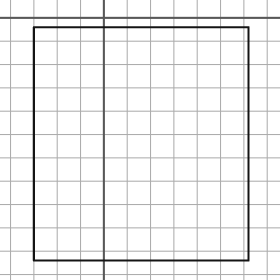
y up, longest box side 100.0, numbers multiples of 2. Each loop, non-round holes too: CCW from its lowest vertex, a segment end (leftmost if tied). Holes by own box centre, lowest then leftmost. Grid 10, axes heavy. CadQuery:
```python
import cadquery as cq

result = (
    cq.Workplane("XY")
    .moveTo(-30.0, -104.0)
    .lineTo(62.0, -104.0)
    .lineTo(62.0, -4.0)
    .lineTo(-30.0, -4.0)
    .close()
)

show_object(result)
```